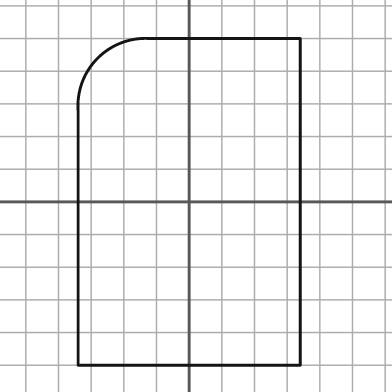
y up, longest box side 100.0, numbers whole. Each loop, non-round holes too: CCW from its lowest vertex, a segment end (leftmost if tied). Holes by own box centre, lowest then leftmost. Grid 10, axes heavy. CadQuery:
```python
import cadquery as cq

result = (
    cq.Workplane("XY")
    .moveTo(-34.0, -50.0)
    .lineTo(34.0, -50.0)
    .lineTo(34.0, 50.0)
    .lineTo(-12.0, 50.0)
    .threePointArc((-28.0, 44.0), (-34.0, 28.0))
    .close()
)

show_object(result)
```